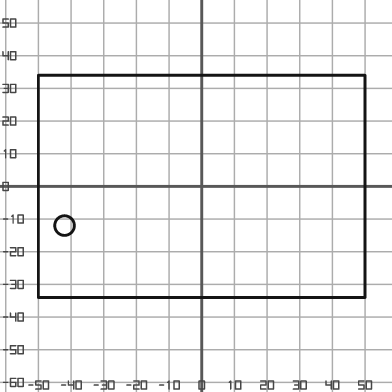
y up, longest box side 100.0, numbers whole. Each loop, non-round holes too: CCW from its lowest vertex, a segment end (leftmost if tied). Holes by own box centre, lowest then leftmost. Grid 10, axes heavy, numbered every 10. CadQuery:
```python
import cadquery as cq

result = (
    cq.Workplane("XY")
    .moveTo(-50.0, -34.0)
    .lineTo(50.0, -34.0)
    .lineTo(50.0, 34.0)
    .lineTo(-50.0, 34.0)
    .close()
    .moveTo(-42.0, -12.0)
    .circle(3.0)
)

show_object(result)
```